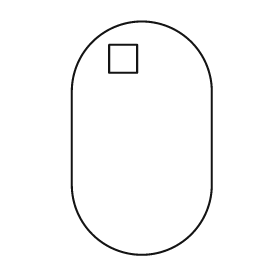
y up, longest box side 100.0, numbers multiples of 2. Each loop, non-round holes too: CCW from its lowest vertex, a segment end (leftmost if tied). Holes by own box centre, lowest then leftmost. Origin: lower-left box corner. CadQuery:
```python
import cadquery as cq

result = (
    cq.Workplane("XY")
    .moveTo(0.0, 30.0)
    .threePointArc((30.0, 0.0), (60.0, 30.0))
    .lineTo(60.0, 70.0)
    .threePointArc((30.0, 100.0), (0.0, 70.0))
    .close()
    .moveTo(16.0, 78.0)
    .lineTo(28.0, 78.0)
    .lineTo(28.0, 90.0)
    .lineTo(16.0, 90.0)
    .close()
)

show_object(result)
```